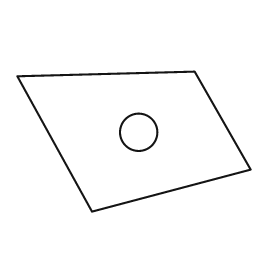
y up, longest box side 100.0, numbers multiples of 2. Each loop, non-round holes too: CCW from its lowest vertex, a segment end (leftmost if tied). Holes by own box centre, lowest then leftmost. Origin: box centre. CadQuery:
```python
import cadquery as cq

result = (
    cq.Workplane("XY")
    .moveTo(-18.0, -30.0)
    .lineTo(50.0, -12.0)
    .lineTo(26.0, 30.0)
    .lineTo(-50.0, 28.0)
    .close()
    .moveTo(2.0, 4.0)
    .circle(8.0)
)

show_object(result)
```